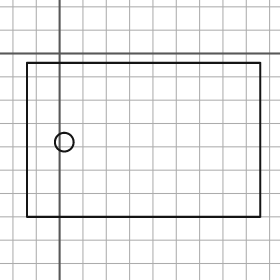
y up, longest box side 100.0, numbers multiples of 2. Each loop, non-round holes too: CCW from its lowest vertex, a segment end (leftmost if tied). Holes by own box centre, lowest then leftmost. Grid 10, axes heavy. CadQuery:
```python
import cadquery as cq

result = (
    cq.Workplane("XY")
    .moveTo(-14.0, -70.0)
    .lineTo(86.0, -70.0)
    .lineTo(86.0, -4.0)
    .lineTo(-14.0, -4.0)
    .close()
    .moveTo(2.0, -38.0)
    .circle(4.0)
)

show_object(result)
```